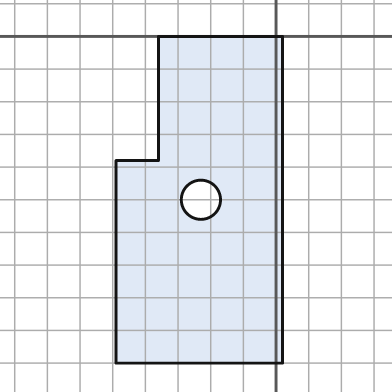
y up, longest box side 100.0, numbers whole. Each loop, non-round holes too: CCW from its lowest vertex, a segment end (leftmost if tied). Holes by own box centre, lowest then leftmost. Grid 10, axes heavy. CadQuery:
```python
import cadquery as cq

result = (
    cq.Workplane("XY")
    .moveTo(-49.0, -100.0)
    .lineTo(2.0, -100.0)
    .lineTo(2.0, 0.0)
    .lineTo(-36.0, 0.0)
    .lineTo(-36.0, -38.0)
    .lineTo(-49.0, -38.0)
    .close()
    .moveTo(-23.0, -50.0)
    .circle(6.0)
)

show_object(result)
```